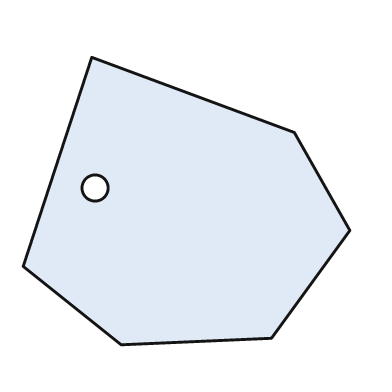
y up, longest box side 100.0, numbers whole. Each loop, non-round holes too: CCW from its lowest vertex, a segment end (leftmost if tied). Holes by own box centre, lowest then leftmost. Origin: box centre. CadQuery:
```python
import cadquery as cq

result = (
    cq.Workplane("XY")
    .moveTo(-20.0, -44.0)
    .lineTo(26.0, -42.0)
    .lineTo(50.0, -9.0)
    .lineTo(33.0, 21.0)
    .lineTo(-29.0, 44.0)
    .lineTo(-50.0, -20.0)
    .close()
    .moveTo(-28.0, 4.0)
    .circle(4.0)
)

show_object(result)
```